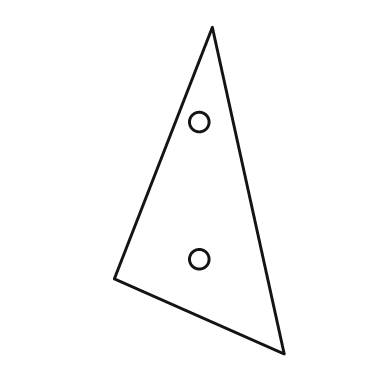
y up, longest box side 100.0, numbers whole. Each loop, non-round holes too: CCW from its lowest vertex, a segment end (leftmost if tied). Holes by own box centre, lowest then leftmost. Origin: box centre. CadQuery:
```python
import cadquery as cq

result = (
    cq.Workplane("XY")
    .moveTo(26.0, -50.0)
    .lineTo(4.0, 50.0)
    .lineTo(-26.0, -27.0)
    .close()
    .moveTo(0.0, -21.0)
    .circle(3.0)
    .moveTo(0.0, 21.0)
    .circle(3.0)
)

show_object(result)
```